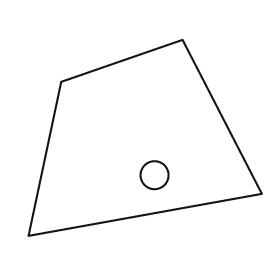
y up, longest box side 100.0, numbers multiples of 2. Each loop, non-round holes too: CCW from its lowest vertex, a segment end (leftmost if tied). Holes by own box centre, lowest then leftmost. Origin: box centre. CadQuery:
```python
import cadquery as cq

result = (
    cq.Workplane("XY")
    .moveTo(-50.0, -42.0)
    .lineTo(50.0, -24.0)
    .lineTo(16.0, 42.0)
    .lineTo(-36.0, 24.0)
    .close()
    .moveTo(4.0, -16.0)
    .circle(6.0)
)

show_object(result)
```